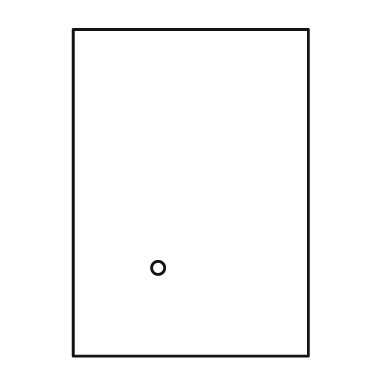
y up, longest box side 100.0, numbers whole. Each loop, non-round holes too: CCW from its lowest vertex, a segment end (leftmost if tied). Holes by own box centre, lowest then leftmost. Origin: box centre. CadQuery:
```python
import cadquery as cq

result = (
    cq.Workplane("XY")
    .moveTo(-36.0, -50.0)
    .lineTo(36.0, -50.0)
    .lineTo(36.0, 50.0)
    .lineTo(-36.0, 50.0)
    .close()
    .moveTo(-10.0, -23.0)
    .circle(2.0)
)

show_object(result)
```